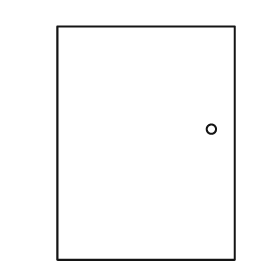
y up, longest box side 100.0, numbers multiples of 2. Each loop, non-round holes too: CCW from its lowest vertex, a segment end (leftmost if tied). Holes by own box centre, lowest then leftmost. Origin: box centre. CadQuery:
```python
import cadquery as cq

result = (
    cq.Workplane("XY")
    .moveTo(-38.0, -50.0)
    .lineTo(38.0, -50.0)
    .lineTo(38.0, 50.0)
    .lineTo(-38.0, 50.0)
    .close()
    .moveTo(28.0, 6.0)
    .circle(2.0)
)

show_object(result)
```